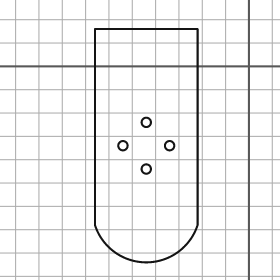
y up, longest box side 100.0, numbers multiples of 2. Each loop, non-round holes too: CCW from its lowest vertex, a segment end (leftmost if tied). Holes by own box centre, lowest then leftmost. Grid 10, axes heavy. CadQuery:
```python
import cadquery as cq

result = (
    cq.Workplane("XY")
    .moveTo(-66.0, -68.0)
    .threePointArc((-44.0, -84.0), (-22.0, -68.0))
    .lineTo(-22.0, 16.0)
    .lineTo(-66.0, 16.0)
    .close()
    .moveTo(-44.0, -44.0)
    .circle(2.0)
    .moveTo(-54.0, -34.0)
    .circle(2.0)
    .moveTo(-34.0, -34.0)
    .circle(2.0)
    .moveTo(-44.0, -24.0)
    .circle(2.0)
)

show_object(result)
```